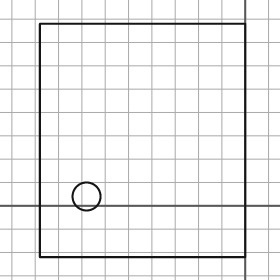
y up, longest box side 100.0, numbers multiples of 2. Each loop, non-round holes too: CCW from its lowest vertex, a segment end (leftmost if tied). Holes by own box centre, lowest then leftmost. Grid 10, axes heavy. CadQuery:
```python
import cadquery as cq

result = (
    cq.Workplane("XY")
    .moveTo(-88.0, -22.0)
    .lineTo(0.0, -22.0)
    .lineTo(0.0, 78.0)
    .lineTo(-88.0, 78.0)
    .close()
    .moveTo(-68.0, 4.0)
    .circle(6.0)
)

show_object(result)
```